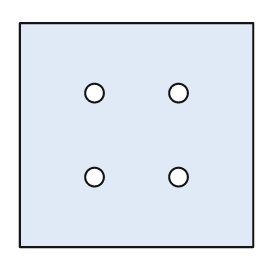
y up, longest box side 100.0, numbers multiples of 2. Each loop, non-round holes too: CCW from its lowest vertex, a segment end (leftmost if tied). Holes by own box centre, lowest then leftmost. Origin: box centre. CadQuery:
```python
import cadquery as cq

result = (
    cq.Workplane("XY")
    .moveTo(-50.0, -48.0)
    .lineTo(50.0, -48.0)
    .lineTo(50.0, 48.0)
    .lineTo(-50.0, 48.0)
    .close()
    .moveTo(-18.0, -18.0)
    .circle(4.0)
    .moveTo(18.0, -18.0)
    .circle(4.0)
    .moveTo(-18.0, 18.0)
    .circle(4.0)
    .moveTo(18.0, 18.0)
    .circle(4.0)
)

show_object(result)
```